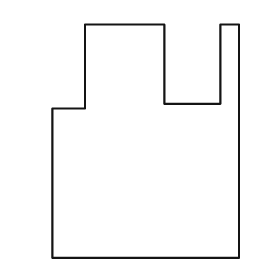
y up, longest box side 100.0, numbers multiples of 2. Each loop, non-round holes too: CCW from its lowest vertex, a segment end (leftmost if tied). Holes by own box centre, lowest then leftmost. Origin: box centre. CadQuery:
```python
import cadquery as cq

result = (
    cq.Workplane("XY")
    .moveTo(-40.0, -50.0)
    .lineTo(40.0, -50.0)
    .lineTo(40.0, 50.0)
    .lineTo(32.0, 50.0)
    .lineTo(32.0, 16.0)
    .lineTo(8.0, 16.0)
    .lineTo(8.0, 50.0)
    .lineTo(-26.0, 50.0)
    .lineTo(-26.0, 14.0)
    .lineTo(-40.0, 14.0)
    .close()
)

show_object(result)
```